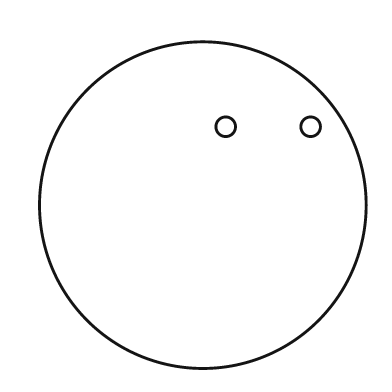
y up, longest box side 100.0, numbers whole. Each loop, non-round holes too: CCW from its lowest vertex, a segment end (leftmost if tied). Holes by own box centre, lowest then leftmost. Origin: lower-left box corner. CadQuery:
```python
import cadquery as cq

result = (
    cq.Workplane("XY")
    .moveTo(50.0, 50.0)
    .circle(50.0)
    .moveTo(57.0, 74.0)
    .circle(3.0)
    .moveTo(83.0, 74.0)
    .circle(3.0)
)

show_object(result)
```